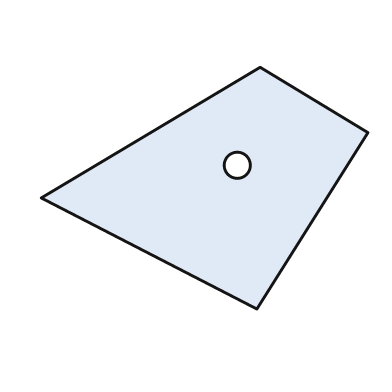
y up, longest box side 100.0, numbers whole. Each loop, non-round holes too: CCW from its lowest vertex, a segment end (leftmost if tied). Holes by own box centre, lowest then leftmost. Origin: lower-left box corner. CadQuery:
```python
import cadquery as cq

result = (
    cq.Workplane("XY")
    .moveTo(66.0, 0.0)
    .lineTo(100.0, 54.0)
    .lineTo(67.0, 74.0)
    .lineTo(0.0, 34.0)
    .close()
    .moveTo(60.0, 44.0)
    .circle(4.0)
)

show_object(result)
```